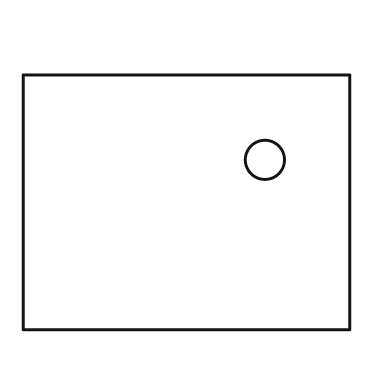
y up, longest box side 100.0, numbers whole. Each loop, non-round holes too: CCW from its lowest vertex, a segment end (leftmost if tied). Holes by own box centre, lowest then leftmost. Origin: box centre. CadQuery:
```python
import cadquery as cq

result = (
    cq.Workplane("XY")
    .moveTo(-50.0, -39.0)
    .lineTo(50.0, -39.0)
    .lineTo(50.0, 39.0)
    .lineTo(-50.0, 39.0)
    .close()
    .moveTo(24.0, 13.0)
    .circle(6.0)
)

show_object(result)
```